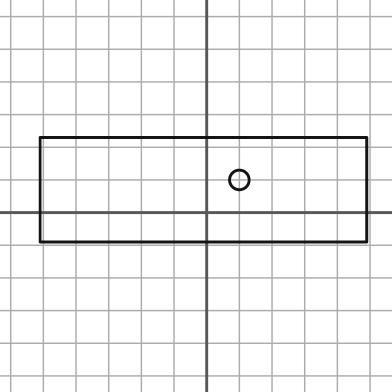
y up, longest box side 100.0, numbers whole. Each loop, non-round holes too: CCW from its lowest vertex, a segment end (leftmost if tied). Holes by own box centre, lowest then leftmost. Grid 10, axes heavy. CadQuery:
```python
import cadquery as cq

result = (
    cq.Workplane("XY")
    .moveTo(-51.0, -9.0)
    .lineTo(49.0, -9.0)
    .lineTo(49.0, 23.0)
    .lineTo(-51.0, 23.0)
    .close()
    .moveTo(10.0, 10.0)
    .circle(3.0)
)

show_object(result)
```